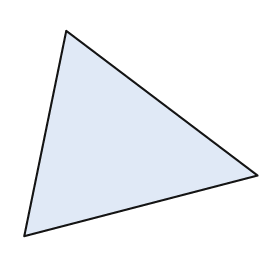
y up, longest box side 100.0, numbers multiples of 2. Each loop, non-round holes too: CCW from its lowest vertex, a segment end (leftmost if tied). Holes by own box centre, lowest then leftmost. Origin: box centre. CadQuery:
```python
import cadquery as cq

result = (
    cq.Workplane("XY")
    .moveTo(-50.0, -44.0)
    .lineTo(50.0, -18.0)
    .lineTo(-32.0, 44.0)
    .close()
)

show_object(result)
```